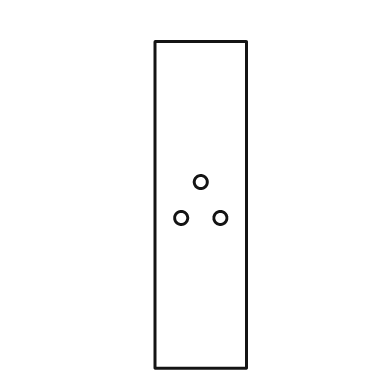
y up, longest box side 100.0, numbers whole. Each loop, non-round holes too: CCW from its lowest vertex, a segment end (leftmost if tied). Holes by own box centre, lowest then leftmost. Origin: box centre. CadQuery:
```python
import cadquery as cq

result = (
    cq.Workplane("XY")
    .moveTo(-14.0, -50.0)
    .lineTo(14.0, -50.0)
    .lineTo(14.0, 50.0)
    .lineTo(-14.0, 50.0)
    .close()
    .moveTo(-6.0, -4.0)
    .circle(2.0)
    .moveTo(6.0, -4.0)
    .circle(2.0)
    .moveTo(0.0, 7.0)
    .circle(2.0)
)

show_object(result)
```